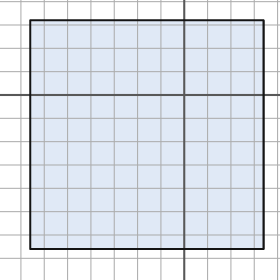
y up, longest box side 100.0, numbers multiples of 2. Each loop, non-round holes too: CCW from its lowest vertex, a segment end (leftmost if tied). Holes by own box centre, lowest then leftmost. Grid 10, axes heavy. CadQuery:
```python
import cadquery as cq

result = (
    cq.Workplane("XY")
    .moveTo(-66.0, -66.0)
    .lineTo(34.0, -66.0)
    .lineTo(34.0, 32.0)
    .lineTo(-66.0, 32.0)
    .close()
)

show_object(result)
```